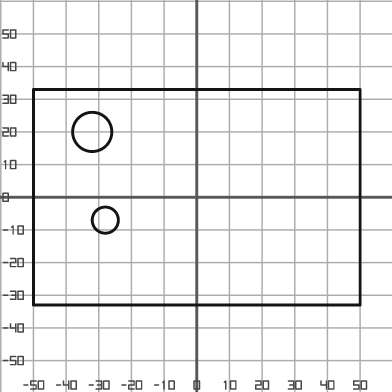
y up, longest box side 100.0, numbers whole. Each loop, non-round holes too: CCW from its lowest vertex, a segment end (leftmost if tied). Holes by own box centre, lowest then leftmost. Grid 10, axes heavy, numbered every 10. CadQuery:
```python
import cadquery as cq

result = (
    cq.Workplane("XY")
    .moveTo(-50.0, -33.0)
    .lineTo(50.0, -33.0)
    .lineTo(50.0, 33.0)
    .lineTo(-50.0, 33.0)
    .close()
    .moveTo(-28.0, -7.0)
    .circle(4.0)
    .moveTo(-32.0, 20.0)
    .circle(6.0)
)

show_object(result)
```